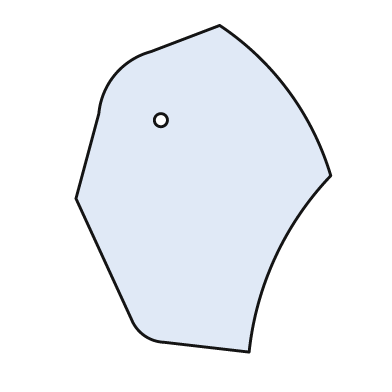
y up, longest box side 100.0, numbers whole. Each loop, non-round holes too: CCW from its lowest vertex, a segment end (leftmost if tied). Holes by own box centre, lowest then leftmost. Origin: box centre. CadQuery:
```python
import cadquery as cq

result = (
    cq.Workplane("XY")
    .moveTo(14.0, -50.0)
    .threePointArc((22.0, -21.0), (39.0, 4.0))
    .threePointArc((26.0, 30.0), (5.0, 50.0))
    .lineTo(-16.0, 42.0)
    .threePointArc((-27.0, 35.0), (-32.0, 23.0))
    .lineTo(-39.0, -3.0)
    .lineTo(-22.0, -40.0)
    .threePointArc((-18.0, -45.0), (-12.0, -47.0))
    .close()
    .moveTo(-13.0, 21.0)
    .circle(2.0)
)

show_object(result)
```